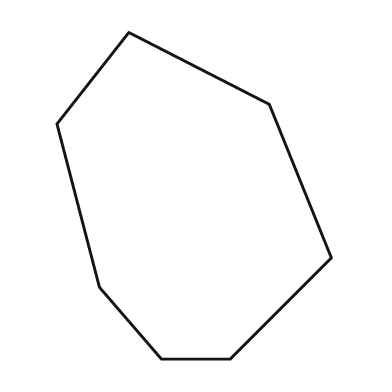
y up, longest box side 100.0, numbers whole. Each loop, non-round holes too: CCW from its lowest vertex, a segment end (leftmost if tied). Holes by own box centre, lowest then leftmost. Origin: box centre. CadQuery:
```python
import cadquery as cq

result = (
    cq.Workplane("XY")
    .moveTo(-10.0, -50.0)
    .lineTo(11.0, -50.0)
    .lineTo(42.0, -19.0)
    .lineTo(23.0, 28.0)
    .lineTo(-20.0, 50.0)
    .lineTo(-42.0, 22.0)
    .lineTo(-29.0, -28.0)
    .close()
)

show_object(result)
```